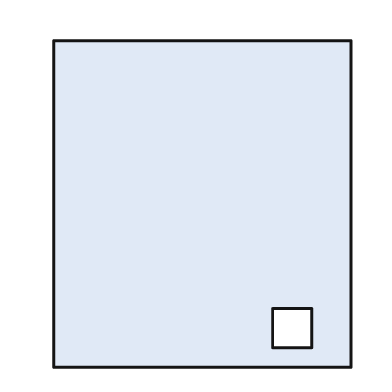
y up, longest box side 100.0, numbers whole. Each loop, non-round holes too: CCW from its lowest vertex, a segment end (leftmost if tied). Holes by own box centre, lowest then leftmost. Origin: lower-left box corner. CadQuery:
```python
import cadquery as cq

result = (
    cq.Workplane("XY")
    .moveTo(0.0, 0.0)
    .lineTo(91.0, 0.0)
    .lineTo(91.0, 100.0)
    .lineTo(0.0, 100.0)
    .close()
    .moveTo(67.0, 6.0)
    .lineTo(79.0, 6.0)
    .lineTo(79.0, 18.0)
    .lineTo(67.0, 18.0)
    .close()
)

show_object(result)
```